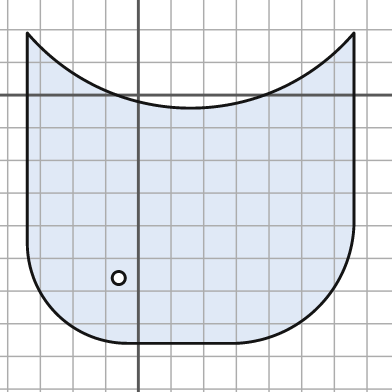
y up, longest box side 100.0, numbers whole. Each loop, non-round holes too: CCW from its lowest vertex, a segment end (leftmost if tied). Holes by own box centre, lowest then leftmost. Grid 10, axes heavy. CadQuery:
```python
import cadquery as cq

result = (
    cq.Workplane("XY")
    .moveTo(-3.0, -76.0)
    .lineTo(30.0, -76.0)
    .threePointArc((55.0, -65.0), (66.0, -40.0))
    .lineTo(66.0, 19.0)
    .threePointArc((16.0, -4.0), (-34.0, 19.0))
    .lineTo(-34.0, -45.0)
    .threePointArc((-25.0, -67.0), (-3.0, -76.0))
    .close()
    .moveTo(-6.0, -56.0)
    .circle(2.0)
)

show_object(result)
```